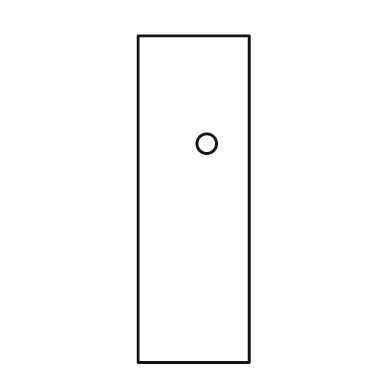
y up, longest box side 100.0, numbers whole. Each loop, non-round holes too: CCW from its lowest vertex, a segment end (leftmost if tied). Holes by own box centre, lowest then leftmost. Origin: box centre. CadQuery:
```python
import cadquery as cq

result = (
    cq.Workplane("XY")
    .moveTo(-17.0, -50.0)
    .lineTo(17.0, -50.0)
    .lineTo(17.0, 50.0)
    .lineTo(-17.0, 50.0)
    .close()
    .moveTo(4.0, 17.0)
    .circle(3.0)
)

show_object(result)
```